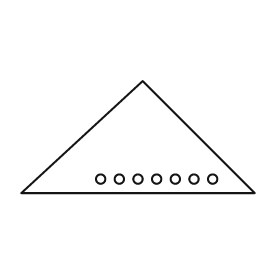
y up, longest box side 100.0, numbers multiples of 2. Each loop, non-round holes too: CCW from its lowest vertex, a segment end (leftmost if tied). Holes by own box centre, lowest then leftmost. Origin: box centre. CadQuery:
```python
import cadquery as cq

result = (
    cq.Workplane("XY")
    .moveTo(-50.0, -24.0)
    .lineTo(50.0, -24.0)
    .lineTo(2.0, 24.0)
    .close()
    .moveTo(-16.0, -18.0)
    .circle(2.0)
    .moveTo(-8.0, -18.0)
    .circle(2.0)
    .moveTo(0.0, -18.0)
    .circle(2.0)
    .moveTo(8.0, -18.0)
    .circle(2.0)
    .moveTo(16.0, -18.0)
    .circle(2.0)
    .moveTo(24.0, -18.0)
    .circle(2.0)
    .moveTo(32.0, -18.0)
    .circle(2.0)
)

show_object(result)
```